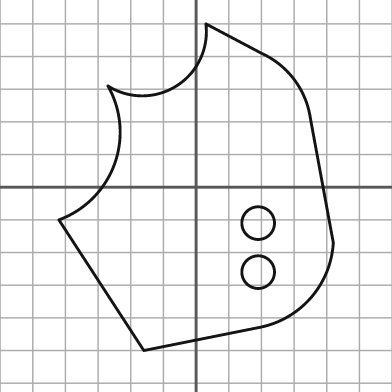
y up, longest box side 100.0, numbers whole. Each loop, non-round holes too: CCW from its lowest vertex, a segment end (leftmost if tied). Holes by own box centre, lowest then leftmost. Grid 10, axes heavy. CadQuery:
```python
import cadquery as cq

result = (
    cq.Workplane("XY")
    .moveTo(-16.0, -50.0)
    .lineTo(19.0, -43.0)
    .threePointArc((35.0, -34.0), (42.0, -17.0))
    .lineTo(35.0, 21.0)
    .threePointArc((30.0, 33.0), (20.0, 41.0))
    .lineTo(3.0, 50.0)
    .threePointArc((-6.0, 31.0), (-27.0, 31.0))
    .threePointArc((-25.0, 7.0), (-42.0, -10.0))
    .close()
    .moveTo(19.0, -26.0)
    .circle(5.0)
    .moveTo(19.0, -11.0)
    .circle(5.0)
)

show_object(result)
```